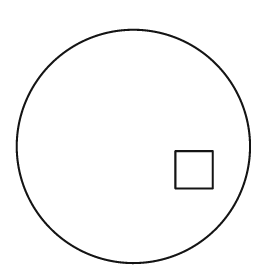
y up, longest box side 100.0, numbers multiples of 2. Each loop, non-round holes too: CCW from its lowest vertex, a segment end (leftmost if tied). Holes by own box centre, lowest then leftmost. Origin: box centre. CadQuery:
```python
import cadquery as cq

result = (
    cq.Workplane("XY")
    .moveTo(0.0, 0.0)
    .circle(50.0)
    .moveTo(18.0, -18.0)
    .lineTo(34.0, -18.0)
    .lineTo(34.0, -2.0)
    .lineTo(18.0, -2.0)
    .close()
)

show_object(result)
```